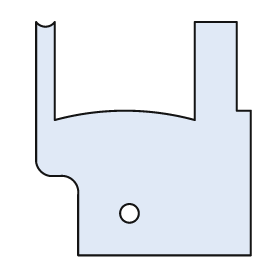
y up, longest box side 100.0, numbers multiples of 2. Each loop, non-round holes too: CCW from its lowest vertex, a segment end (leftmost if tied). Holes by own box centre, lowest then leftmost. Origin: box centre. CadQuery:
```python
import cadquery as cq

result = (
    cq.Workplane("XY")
    .moveTo(-28.0, -50.0)
    .lineTo(46.0, -50.0)
    .lineTo(46.0, 12.0)
    .lineTo(40.0, 12.0)
    .lineTo(40.0, 50.0)
    .lineTo(22.0, 50.0)
    .lineTo(22.0, 8.0)
    .threePointArc((-8.0, 12.0), (-38.0, 8.0))
    .lineTo(-38.0, 50.0)
    .threePointArc((-42.0, 48.0), (-46.0, 50.0))
    .lineTo(-46.0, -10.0)
    .threePointArc((-44.0, -14.0), (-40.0, -16.0))
    .lineTo(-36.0, -16.0)
    .threePointArc((-30.0, -18.0), (-28.0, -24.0))
    .close()
    .moveTo(-6.0, -32.0)
    .circle(4.0)
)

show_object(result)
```